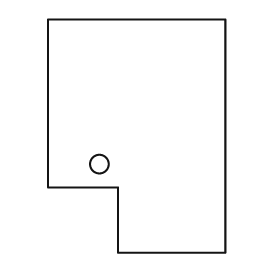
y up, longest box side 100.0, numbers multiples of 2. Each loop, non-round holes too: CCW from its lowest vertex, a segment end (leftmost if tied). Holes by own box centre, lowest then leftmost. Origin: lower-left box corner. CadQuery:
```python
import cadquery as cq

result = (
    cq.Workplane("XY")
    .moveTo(30.0, 0.0)
    .lineTo(76.0, 0.0)
    .lineTo(76.0, 100.0)
    .lineTo(0.0, 100.0)
    .lineTo(0.0, 28.0)
    .lineTo(30.0, 28.0)
    .close()
    .moveTo(22.0, 38.0)
    .circle(4.0)
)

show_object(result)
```